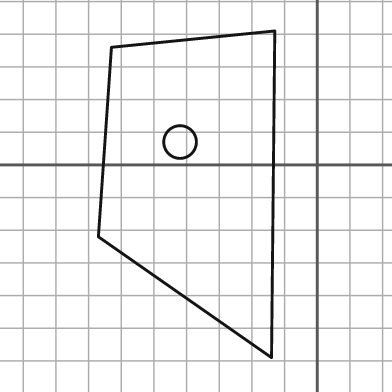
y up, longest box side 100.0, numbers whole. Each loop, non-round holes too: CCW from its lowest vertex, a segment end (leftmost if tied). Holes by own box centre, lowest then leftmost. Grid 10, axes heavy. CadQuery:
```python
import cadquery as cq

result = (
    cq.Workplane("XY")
    .moveTo(-14.0, -59.0)
    .lineTo(-13.0, 41.0)
    .lineTo(-63.0, 36.0)
    .lineTo(-67.0, -22.0)
    .close()
    .moveTo(-42.0, 7.0)
    .circle(5.0)
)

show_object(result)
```